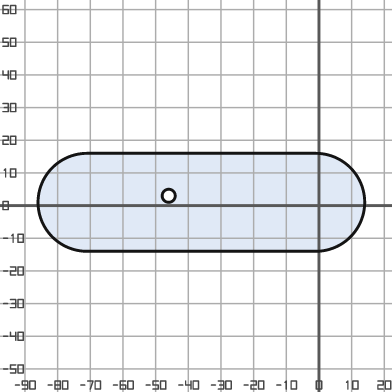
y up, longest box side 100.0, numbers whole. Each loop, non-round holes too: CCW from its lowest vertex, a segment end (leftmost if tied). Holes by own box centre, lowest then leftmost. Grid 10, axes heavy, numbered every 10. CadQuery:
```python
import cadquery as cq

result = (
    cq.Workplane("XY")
    .moveTo(-71.0, -14.0)
    .lineTo(-1.0, -14.0)
    .threePointArc((14.0, 1.0), (-1.0, 16.0))
    .lineTo(-71.0, 16.0)
    .threePointArc((-86.0, 1.0), (-71.0, -14.0))
    .close()
    .moveTo(-46.0, 3.0)
    .circle(2.0)
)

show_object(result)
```